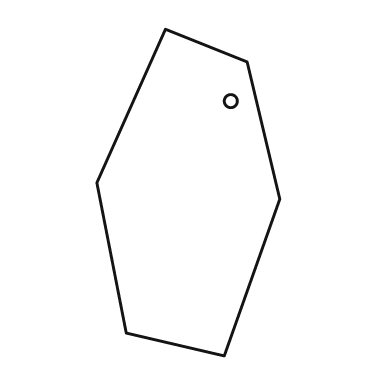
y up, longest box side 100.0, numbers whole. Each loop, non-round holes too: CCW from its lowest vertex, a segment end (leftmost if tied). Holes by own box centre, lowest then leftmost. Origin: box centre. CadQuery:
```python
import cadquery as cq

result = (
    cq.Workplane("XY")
    .moveTo(11.0, -50.0)
    .lineTo(28.0, -2.0)
    .lineTo(18.0, 40.0)
    .lineTo(-7.0, 50.0)
    .lineTo(-28.0, 3.0)
    .lineTo(-19.0, -43.0)
    .close()
    .moveTo(13.0, 28.0)
    .circle(2.0)
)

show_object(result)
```